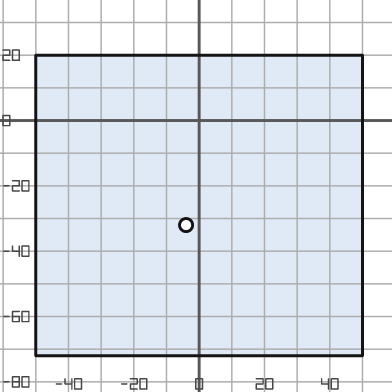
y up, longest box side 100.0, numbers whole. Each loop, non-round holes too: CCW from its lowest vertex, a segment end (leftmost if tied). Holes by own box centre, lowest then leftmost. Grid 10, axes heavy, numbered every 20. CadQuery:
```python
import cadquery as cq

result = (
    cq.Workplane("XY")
    .moveTo(-50.0, -72.0)
    .lineTo(50.0, -72.0)
    .lineTo(50.0, 20.0)
    .lineTo(-50.0, 20.0)
    .close()
    .moveTo(-4.0, -32.0)
    .circle(2.0)
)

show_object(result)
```